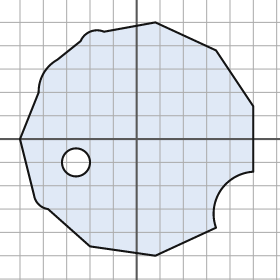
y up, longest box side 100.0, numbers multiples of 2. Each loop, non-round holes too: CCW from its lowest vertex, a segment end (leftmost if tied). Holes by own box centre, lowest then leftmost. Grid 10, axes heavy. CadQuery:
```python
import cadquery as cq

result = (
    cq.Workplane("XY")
    .moveTo(8.0, -50.0)
    .lineTo(34.0, -38.0)
    .threePointArc((36.0, -22.0), (50.0, -14.0))
    .lineTo(50.0, 14.0)
    .lineTo(34.0, 38.0)
    .lineTo(8.0, 50.0)
    .lineTo(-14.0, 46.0)
    .threePointArc((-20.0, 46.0), (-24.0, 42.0))
    .lineTo(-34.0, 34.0)
    .threePointArc((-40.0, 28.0), (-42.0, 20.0))
    .lineTo(-50.0, 0.0)
    .lineTo(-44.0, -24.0)
    .threePointArc((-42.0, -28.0), (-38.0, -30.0))
    .lineTo(-20.0, -46.0)
    .close()
    .moveTo(-26.0, -10.0)
    .circle(6.0)
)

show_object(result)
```